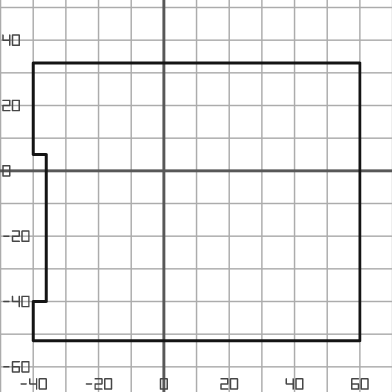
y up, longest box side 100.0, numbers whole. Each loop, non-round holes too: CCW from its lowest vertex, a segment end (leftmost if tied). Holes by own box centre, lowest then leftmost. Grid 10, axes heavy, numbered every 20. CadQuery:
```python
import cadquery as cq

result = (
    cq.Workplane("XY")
    .moveTo(-40.0, -52.0)
    .lineTo(60.0, -52.0)
    .lineTo(60.0, 33.0)
    .lineTo(-40.0, 33.0)
    .lineTo(-40.0, 5.0)
    .lineTo(-36.0, 5.0)
    .lineTo(-36.0, -40.0)
    .lineTo(-40.0, -40.0)
    .close()
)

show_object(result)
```